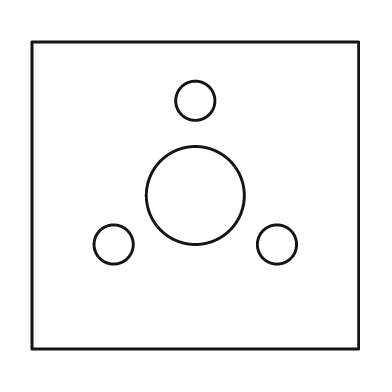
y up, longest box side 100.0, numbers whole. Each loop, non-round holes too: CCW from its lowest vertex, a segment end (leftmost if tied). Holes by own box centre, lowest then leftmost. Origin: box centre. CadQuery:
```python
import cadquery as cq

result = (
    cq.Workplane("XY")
    .moveTo(-50.0, -47.0)
    .lineTo(50.0, -47.0)
    .lineTo(50.0, 47.0)
    .lineTo(-50.0, 47.0)
    .close()
    .moveTo(-25.0, -15.0)
    .circle(6.0)
    .moveTo(25.0, -15.0)
    .circle(6.0)
    .moveTo(0.0, 0.0)
    .circle(15.0)
    .moveTo(0.0, 29.0)
    .circle(6.0)
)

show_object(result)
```